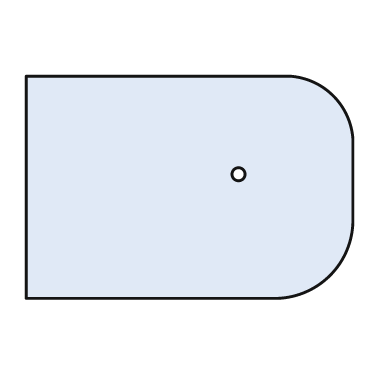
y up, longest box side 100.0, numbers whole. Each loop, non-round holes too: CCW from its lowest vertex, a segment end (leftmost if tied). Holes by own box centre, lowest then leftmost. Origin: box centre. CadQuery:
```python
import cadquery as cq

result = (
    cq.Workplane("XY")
    .moveTo(-50.0, -34.0)
    .lineTo(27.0, -34.0)
    .threePointArc((43.0, -27.0), (50.0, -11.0))
    .lineTo(50.0, 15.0)
    .threePointArc((44.0, 28.0), (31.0, 34.0))
    .lineTo(-50.0, 34.0)
    .close()
    .moveTo(15.0, 4.0)
    .circle(2.0)
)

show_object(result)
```